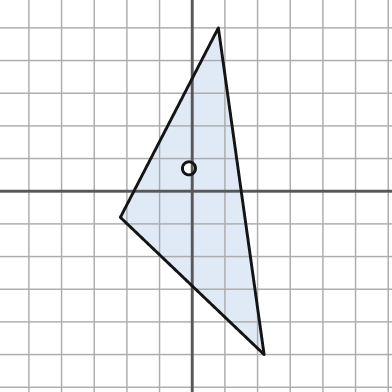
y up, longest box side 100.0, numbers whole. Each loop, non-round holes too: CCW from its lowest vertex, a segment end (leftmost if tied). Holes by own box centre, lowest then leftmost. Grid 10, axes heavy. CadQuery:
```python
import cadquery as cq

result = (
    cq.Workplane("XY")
    .moveTo(22.0, -50.0)
    .lineTo(8.0, 50.0)
    .lineTo(-22.0, -8.0)
    .close()
    .moveTo(-1.0, 7.0)
    .circle(2.0)
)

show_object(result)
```